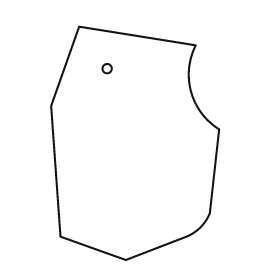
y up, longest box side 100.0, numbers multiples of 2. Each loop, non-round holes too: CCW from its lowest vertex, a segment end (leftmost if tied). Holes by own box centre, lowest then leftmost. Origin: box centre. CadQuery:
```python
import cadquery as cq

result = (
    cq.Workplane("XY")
    .moveTo(-4.0, -50.0)
    .lineTo(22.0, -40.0)
    .threePointArc((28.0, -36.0), (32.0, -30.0))
    .lineTo(36.0, 6.0)
    .threePointArc((24.0, 22.0), (26.0, 42.0))
    .lineTo(-24.0, 50.0)
    .lineTo(-36.0, 16.0)
    .lineTo(-32.0, -40.0)
    .close()
    .moveTo(-12.0, 32.0)
    .circle(2.0)
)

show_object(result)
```